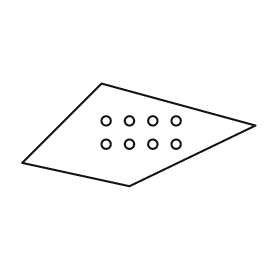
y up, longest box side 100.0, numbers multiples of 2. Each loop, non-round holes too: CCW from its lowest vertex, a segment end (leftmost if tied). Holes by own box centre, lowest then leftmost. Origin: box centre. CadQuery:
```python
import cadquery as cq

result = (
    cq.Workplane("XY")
    .moveTo(-4.0, -22.0)
    .lineTo(50.0, 4.0)
    .lineTo(-16.0, 22.0)
    .lineTo(-50.0, -12.0)
    .close()
    .moveTo(-14.0, -4.0)
    .circle(2.0)
    .moveTo(-4.0, -4.0)
    .circle(2.0)
    .moveTo(6.0, -4.0)
    .circle(2.0)
    .moveTo(16.0, -4.0)
    .circle(2.0)
    .moveTo(-14.0, 6.0)
    .circle(2.0)
    .moveTo(-4.0, 6.0)
    .circle(2.0)
    .moveTo(6.0, 6.0)
    .circle(2.0)
    .moveTo(16.0, 6.0)
    .circle(2.0)
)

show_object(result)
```